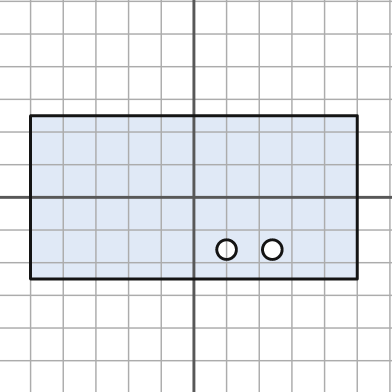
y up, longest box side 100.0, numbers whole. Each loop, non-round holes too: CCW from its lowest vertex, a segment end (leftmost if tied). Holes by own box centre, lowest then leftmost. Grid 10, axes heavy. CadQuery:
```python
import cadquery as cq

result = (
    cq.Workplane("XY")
    .moveTo(-50.0, -25.0)
    .lineTo(50.0, -25.0)
    .lineTo(50.0, 25.0)
    .lineTo(-50.0, 25.0)
    .close()
    .moveTo(10.0, -16.0)
    .circle(3.0)
    .moveTo(24.0, -16.0)
    .circle(3.0)
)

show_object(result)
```